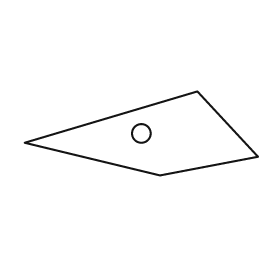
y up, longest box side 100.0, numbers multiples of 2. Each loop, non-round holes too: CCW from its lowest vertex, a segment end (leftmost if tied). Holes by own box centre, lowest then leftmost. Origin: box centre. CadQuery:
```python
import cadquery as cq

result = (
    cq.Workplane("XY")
    .moveTo(8.0, -18.0)
    .lineTo(50.0, -10.0)
    .lineTo(24.0, 18.0)
    .lineTo(-50.0, -4.0)
    .close()
    .moveTo(0.0, 0.0)
    .circle(4.0)
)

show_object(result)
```